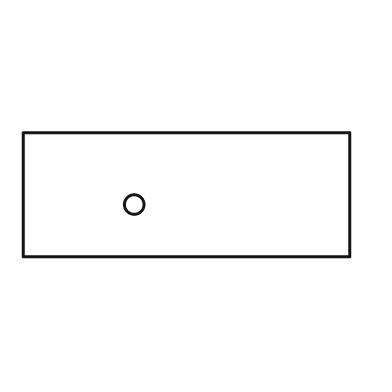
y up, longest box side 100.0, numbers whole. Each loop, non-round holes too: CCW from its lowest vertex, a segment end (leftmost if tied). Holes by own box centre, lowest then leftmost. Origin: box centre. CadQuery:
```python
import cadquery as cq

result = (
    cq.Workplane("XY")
    .moveTo(-50.0, -19.0)
    .lineTo(50.0, -19.0)
    .lineTo(50.0, 19.0)
    .lineTo(-50.0, 19.0)
    .close()
    .moveTo(-16.0, -3.0)
    .circle(3.0)
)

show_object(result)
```